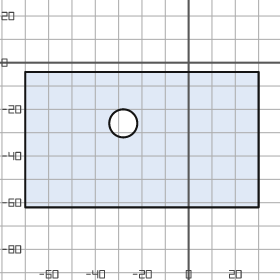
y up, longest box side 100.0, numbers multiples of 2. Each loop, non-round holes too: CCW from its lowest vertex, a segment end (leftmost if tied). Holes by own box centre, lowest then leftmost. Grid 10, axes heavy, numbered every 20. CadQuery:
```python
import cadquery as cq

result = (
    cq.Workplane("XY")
    .moveTo(-70.0, -62.0)
    .lineTo(30.0, -62.0)
    .lineTo(30.0, -4.0)
    .lineTo(-70.0, -4.0)
    .close()
    .moveTo(-28.0, -26.0)
    .circle(6.0)
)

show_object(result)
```